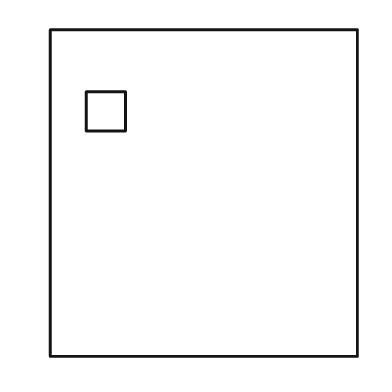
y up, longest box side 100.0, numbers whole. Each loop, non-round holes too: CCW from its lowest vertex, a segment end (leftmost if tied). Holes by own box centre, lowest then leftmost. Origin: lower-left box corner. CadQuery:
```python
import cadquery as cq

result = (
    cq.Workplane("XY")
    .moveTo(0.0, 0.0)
    .lineTo(94.0, 0.0)
    .lineTo(94.0, 100.0)
    .lineTo(0.0, 100.0)
    .close()
    .moveTo(11.0, 69.0)
    .lineTo(23.0, 69.0)
    .lineTo(23.0, 81.0)
    .lineTo(11.0, 81.0)
    .close()
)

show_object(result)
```